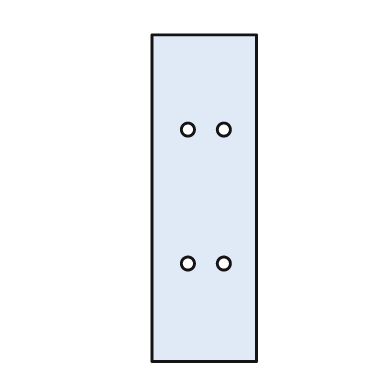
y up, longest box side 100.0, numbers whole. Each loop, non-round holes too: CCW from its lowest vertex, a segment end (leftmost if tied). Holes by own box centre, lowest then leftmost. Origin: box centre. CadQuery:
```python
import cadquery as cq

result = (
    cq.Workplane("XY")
    .moveTo(-16.0, -50.0)
    .lineTo(16.0, -50.0)
    .lineTo(16.0, 50.0)
    .lineTo(-16.0, 50.0)
    .close()
    .moveTo(-5.0, -20.0)
    .circle(2.0)
    .moveTo(6.0, -20.0)
    .circle(2.0)
    .moveTo(-5.0, 21.0)
    .circle(2.0)
    .moveTo(6.0, 21.0)
    .circle(2.0)
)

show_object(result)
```